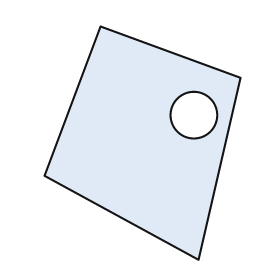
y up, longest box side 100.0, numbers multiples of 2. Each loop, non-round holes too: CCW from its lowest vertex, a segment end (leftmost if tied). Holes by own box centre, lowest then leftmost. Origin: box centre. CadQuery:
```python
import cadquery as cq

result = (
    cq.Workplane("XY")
    .moveTo(24.0, -50.0)
    .lineTo(42.0, 28.0)
    .lineTo(-18.0, 50.0)
    .lineTo(-42.0, -14.0)
    .close()
    .moveTo(22.0, 12.0)
    .circle(10.0)
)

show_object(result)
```